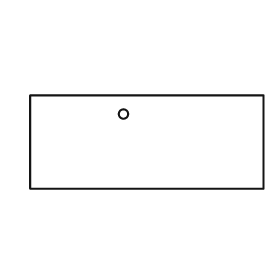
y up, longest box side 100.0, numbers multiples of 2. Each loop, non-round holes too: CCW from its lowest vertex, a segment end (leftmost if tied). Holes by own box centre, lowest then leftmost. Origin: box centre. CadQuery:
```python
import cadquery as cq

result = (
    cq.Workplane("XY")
    .moveTo(-50.0, -20.0)
    .lineTo(50.0, -20.0)
    .lineTo(50.0, 20.0)
    .lineTo(-50.0, 20.0)
    .close()
    .moveTo(-10.0, 12.0)
    .circle(2.0)
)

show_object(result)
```